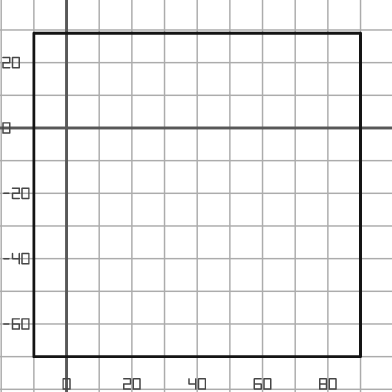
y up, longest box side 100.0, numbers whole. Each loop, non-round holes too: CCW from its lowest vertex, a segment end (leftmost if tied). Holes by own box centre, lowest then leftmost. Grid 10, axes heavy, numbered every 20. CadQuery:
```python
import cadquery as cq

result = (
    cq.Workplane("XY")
    .moveTo(-10.0, -70.0)
    .lineTo(90.0, -70.0)
    .lineTo(90.0, 29.0)
    .lineTo(-10.0, 29.0)
    .close()
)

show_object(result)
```